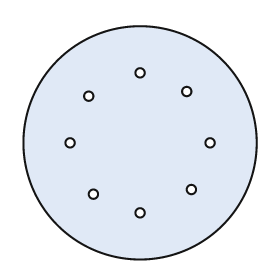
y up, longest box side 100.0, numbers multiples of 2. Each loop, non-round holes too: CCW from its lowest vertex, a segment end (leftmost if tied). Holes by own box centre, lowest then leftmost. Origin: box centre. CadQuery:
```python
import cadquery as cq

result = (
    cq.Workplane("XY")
    .moveTo(0.0, 0.0)
    .circle(50.0)
    .moveTo(0.0, -30.0)
    .circle(2.0)
    .moveTo(-20.0, -22.0)
    .circle(2.0)
    .moveTo(22.0, -20.0)
    .circle(2.0)
    .moveTo(-30.0, 0.0)
    .circle(2.0)
    .moveTo(30.0, 0.0)
    .circle(2.0)
    .moveTo(-22.0, 20.0)
    .circle(2.0)
    .moveTo(20.0, 22.0)
    .circle(2.0)
    .moveTo(0.0, 30.0)
    .circle(2.0)
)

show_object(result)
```